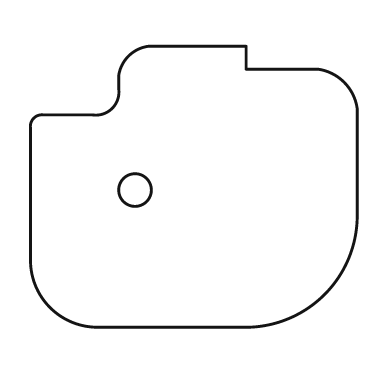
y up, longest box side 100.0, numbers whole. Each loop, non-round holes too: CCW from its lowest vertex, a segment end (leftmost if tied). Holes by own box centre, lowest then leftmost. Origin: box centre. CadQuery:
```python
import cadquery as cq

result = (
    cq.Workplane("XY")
    .moveTo(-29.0, -43.0)
    .lineTo(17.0, -43.0)
    .threePointArc((40.0, -33.0), (50.0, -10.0))
    .lineTo(50.0, 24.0)
    .threePointArc((46.0, 32.0), (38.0, 36.0))
    .lineTo(16.0, 36.0)
    .lineTo(16.0, 43.0)
    .lineTo(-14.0, 43.0)
    .threePointArc((-20.0, 40.0), (-23.0, 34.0))
    .lineTo(-23.0, 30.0)
    .threePointArc((-25.0, 24.0), (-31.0, 22.0))
    .lineTo(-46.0, 22.0)
    .threePointArc((-49.0, 21.0), (-50.0, 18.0))
    .lineTo(-50.0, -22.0)
    .threePointArc((-44.0, -37.0), (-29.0, -43.0))
    .close()
    .moveTo(-18.0, -1.0)
    .circle(5.0)
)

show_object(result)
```